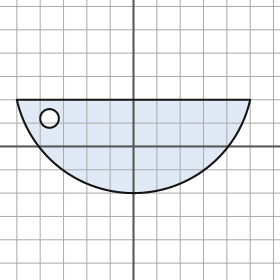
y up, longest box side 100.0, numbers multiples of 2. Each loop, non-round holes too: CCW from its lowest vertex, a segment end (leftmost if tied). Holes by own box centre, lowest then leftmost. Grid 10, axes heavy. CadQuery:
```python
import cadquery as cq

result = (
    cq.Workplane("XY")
    .moveTo(-50.0, 20.0)
    .threePointArc((0.0, -20.0), (50.0, 20.0))
    .close()
    .moveTo(-36.0, 12.0)
    .circle(4.0)
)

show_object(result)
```